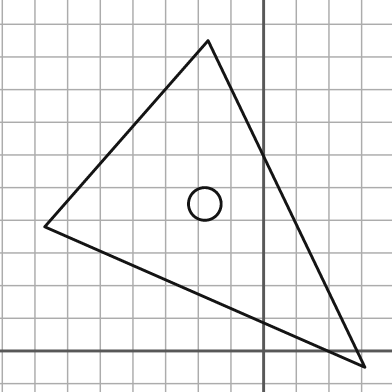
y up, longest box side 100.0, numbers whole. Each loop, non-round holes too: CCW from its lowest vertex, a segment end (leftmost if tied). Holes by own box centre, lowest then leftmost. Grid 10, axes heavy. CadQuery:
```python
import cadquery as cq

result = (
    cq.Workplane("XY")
    .moveTo(31.0, -5.0)
    .lineTo(-17.0, 95.0)
    .lineTo(-67.0, 38.0)
    .close()
    .moveTo(-18.0, 45.0)
    .circle(5.0)
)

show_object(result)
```